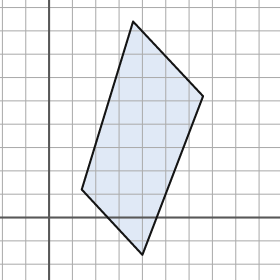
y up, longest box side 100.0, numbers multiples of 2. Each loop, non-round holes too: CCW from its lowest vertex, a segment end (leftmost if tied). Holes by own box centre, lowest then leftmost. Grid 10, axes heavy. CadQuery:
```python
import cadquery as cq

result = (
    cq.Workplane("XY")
    .moveTo(40.0, -16.0)
    .lineTo(66.0, 52.0)
    .lineTo(36.0, 84.0)
    .lineTo(14.0, 12.0)
    .close()
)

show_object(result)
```